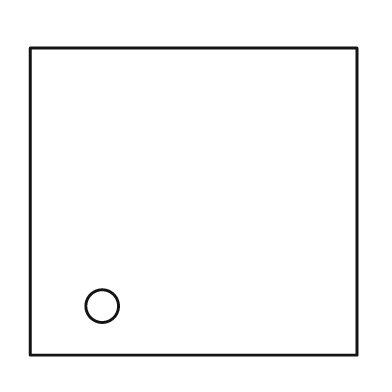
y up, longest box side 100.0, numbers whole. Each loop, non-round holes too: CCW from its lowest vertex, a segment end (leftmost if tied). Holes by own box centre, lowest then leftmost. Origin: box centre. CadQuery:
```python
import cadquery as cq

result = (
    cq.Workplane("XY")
    .moveTo(-50.0, -47.0)
    .lineTo(50.0, -47.0)
    .lineTo(50.0, 47.0)
    .lineTo(-50.0, 47.0)
    .close()
    .moveTo(-28.0, -32.0)
    .circle(5.0)
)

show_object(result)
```